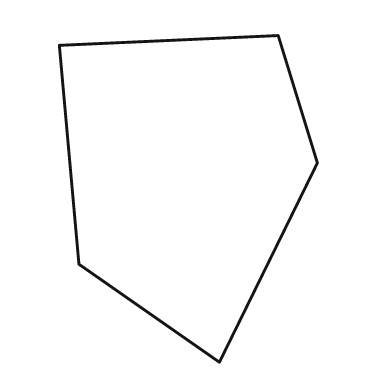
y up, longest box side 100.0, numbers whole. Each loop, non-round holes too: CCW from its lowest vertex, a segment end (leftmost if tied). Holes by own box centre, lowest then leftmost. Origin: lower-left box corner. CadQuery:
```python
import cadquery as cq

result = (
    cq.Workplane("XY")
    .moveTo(49.0, 0.0)
    .lineTo(79.0, 61.0)
    .lineTo(67.0, 100.0)
    .lineTo(0.0, 97.0)
    .lineTo(6.0, 30.0)
    .close()
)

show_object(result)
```